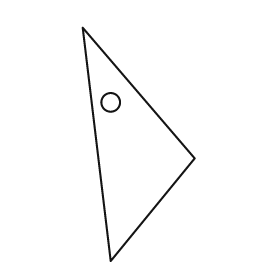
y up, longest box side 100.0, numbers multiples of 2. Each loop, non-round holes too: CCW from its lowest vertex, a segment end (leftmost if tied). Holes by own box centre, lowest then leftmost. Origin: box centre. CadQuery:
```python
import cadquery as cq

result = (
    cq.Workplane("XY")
    .moveTo(-12.0, -50.0)
    .lineTo(24.0, -6.0)
    .lineTo(-24.0, 50.0)
    .close()
    .moveTo(-12.0, 18.0)
    .circle(4.0)
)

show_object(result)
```